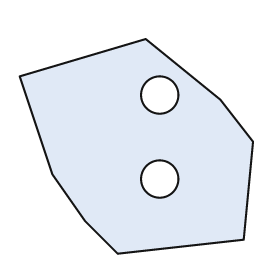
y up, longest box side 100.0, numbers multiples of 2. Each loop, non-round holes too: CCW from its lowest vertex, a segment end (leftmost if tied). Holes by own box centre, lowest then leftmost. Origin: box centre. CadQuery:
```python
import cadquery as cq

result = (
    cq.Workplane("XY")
    .moveTo(-8.0, -46.0)
    .lineTo(46.0, -40.0)
    .lineTo(50.0, 2.0)
    .lineTo(36.0, 20.0)
    .lineTo(4.0, 46.0)
    .lineTo(-50.0, 30.0)
    .lineTo(-36.0, -12.0)
    .lineTo(-22.0, -32.0)
    .close()
    .moveTo(10.0, -14.0)
    .circle(8.0)
    .moveTo(10.0, 22.0)
    .circle(8.0)
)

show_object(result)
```